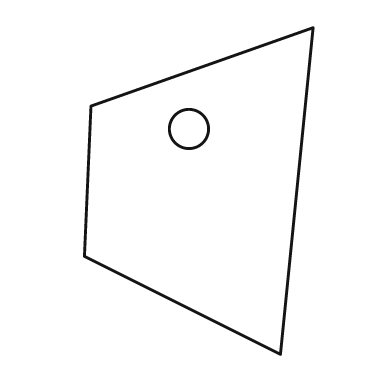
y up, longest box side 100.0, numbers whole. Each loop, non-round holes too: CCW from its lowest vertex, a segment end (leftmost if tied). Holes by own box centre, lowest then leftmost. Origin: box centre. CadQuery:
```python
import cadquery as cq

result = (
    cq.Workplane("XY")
    .moveTo(25.0, -50.0)
    .lineTo(35.0, 50.0)
    .lineTo(-33.0, 26.0)
    .lineTo(-35.0, -20.0)
    .close()
    .moveTo(-3.0, 19.0)
    .circle(6.0)
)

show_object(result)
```